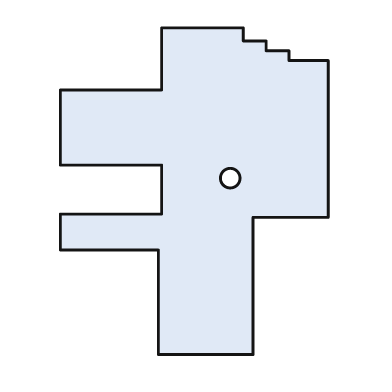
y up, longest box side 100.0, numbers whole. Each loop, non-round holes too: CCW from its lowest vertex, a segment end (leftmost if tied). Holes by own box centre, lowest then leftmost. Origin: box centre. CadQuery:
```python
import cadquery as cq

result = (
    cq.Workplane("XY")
    .moveTo(-11.0, -50.0)
    .lineTo(18.0, -50.0)
    .lineTo(18.0, -8.0)
    .lineTo(41.0, -8.0)
    .lineTo(41.0, 40.0)
    .lineTo(29.0, 40.0)
    .lineTo(29.0, 43.0)
    .lineTo(22.0, 43.0)
    .lineTo(22.0, 46.0)
    .lineTo(15.0, 46.0)
    .lineTo(15.0, 50.0)
    .lineTo(-10.0, 50.0)
    .lineTo(-10.0, 31.0)
    .lineTo(-41.0, 31.0)
    .lineTo(-41.0, 8.0)
    .lineTo(-10.0, 8.0)
    .lineTo(-10.0, -7.0)
    .lineTo(-41.0, -7.0)
    .lineTo(-41.0, -18.0)
    .lineTo(-11.0, -18.0)
    .close()
    .moveTo(11.0, 4.0)
    .circle(3.0)
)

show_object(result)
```